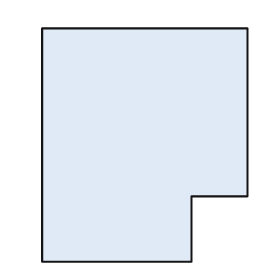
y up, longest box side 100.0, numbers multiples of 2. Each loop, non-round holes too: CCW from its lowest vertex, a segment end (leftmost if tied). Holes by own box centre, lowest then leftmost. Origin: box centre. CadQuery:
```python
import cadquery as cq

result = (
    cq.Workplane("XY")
    .moveTo(-44.0, -50.0)
    .lineTo(20.0, -50.0)
    .lineTo(20.0, -22.0)
    .lineTo(44.0, -22.0)
    .lineTo(44.0, 50.0)
    .lineTo(-44.0, 50.0)
    .close()
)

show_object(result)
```